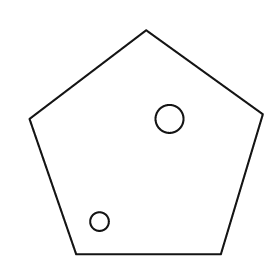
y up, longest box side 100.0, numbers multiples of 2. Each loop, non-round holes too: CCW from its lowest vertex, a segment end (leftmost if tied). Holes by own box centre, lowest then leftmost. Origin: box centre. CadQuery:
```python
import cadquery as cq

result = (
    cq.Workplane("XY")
    .moveTo(-30.0, -48.0)
    .lineTo(32.0, -48.0)
    .lineTo(50.0, 12.0)
    .lineTo(0.0, 48.0)
    .lineTo(-50.0, 10.0)
    .close()
    .moveTo(-20.0, -34.0)
    .circle(4.0)
    .moveTo(10.0, 10.0)
    .circle(6.0)
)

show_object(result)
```